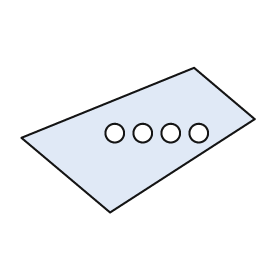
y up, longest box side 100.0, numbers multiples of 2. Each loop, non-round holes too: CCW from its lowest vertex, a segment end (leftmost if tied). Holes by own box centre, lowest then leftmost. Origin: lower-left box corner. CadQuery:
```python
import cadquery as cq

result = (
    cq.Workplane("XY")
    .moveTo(38.0, 0.0)
    .lineTo(100.0, 40.0)
    .lineTo(74.0, 62.0)
    .lineTo(0.0, 32.0)
    .close()
    .moveTo(40.0, 34.0)
    .circle(4.0)
    .moveTo(52.0, 34.0)
    .circle(4.0)
    .moveTo(64.0, 34.0)
    .circle(4.0)
    .moveTo(76.0, 34.0)
    .circle(4.0)
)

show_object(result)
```